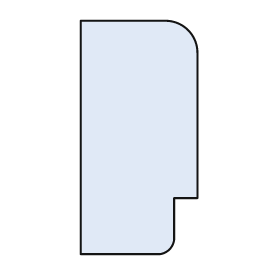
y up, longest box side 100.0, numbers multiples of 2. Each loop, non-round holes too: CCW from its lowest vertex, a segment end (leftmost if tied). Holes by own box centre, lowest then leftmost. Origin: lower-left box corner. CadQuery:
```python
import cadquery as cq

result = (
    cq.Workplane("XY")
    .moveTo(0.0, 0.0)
    .lineTo(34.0, 0.0)
    .threePointArc((38.0, 2.0), (40.0, 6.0))
    .lineTo(40.0, 24.0)
    .lineTo(50.0, 24.0)
    .lineTo(50.0, 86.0)
    .threePointArc((46.0, 96.0), (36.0, 100.0))
    .lineTo(0.0, 100.0)
    .close()
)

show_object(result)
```